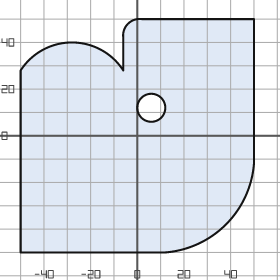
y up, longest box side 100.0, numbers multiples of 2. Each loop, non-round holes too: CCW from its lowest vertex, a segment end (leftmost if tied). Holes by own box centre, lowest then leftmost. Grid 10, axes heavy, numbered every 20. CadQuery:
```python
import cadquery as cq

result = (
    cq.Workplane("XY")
    .moveTo(-50.0, -50.0)
    .lineTo(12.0, -50.0)
    .threePointArc((38.0, -38.0), (50.0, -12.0))
    .lineTo(50.0, 50.0)
    .lineTo(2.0, 50.0)
    .threePointArc((-4.0, 48.0), (-6.0, 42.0))
    .lineTo(-6.0, 28.0)
    .threePointArc((-28.0, 40.0), (-50.0, 28.0))
    .close()
    .moveTo(6.0, 12.0)
    .circle(6.0)
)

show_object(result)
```